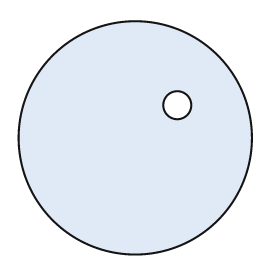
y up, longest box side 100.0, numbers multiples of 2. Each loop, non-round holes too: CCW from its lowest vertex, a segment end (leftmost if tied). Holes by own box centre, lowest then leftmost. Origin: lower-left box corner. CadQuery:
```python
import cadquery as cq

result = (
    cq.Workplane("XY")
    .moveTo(50.0, 50.0)
    .circle(50.0)
    .moveTo(68.0, 64.0)
    .circle(6.0)
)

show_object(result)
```